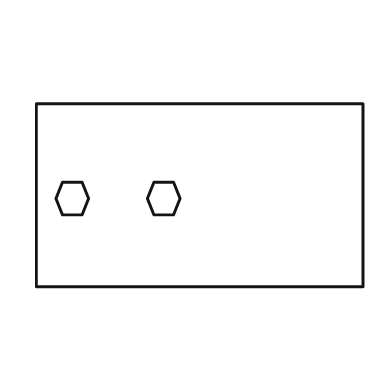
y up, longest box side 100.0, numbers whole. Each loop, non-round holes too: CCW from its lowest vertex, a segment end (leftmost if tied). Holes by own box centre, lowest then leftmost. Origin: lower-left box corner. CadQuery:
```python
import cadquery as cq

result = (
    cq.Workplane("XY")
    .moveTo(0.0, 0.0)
    .lineTo(100.0, 0.0)
    .lineTo(100.0, 56.0)
    .lineTo(0.0, 56.0)
    .close()
    .moveTo(8.0, 22.0)
    .lineTo(14.0, 22.0)
    .lineTo(16.0, 27.0)
    .lineTo(14.0, 32.0)
    .lineTo(8.0, 32.0)
    .lineTo(6.0, 27.0)
    .close()
    .moveTo(36.0, 22.0)
    .lineTo(42.0, 22.0)
    .lineTo(44.0, 27.0)
    .lineTo(42.0, 32.0)
    .lineTo(36.0, 32.0)
    .lineTo(34.0, 27.0)
    .close()
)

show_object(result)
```